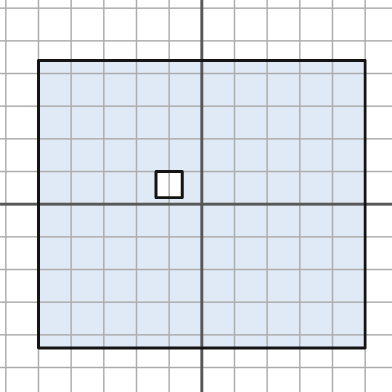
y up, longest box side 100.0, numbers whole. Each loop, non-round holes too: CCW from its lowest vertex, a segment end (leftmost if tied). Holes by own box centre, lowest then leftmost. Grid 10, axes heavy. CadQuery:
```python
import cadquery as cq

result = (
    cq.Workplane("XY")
    .moveTo(-50.0, -44.0)
    .lineTo(50.0, -44.0)
    .lineTo(50.0, 44.0)
    .lineTo(-50.0, 44.0)
    .close()
    .moveTo(-14.0, 2.0)
    .lineTo(-6.0, 2.0)
    .lineTo(-6.0, 10.0)
    .lineTo(-14.0, 10.0)
    .close()
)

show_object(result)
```